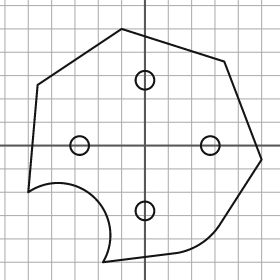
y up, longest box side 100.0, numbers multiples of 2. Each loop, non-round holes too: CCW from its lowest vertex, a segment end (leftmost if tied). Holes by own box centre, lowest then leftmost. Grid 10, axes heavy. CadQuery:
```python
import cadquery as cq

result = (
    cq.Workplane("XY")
    .moveTo(-18.0, -50.0)
    .lineTo(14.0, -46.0)
    .threePointArc((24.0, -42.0), (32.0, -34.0))
    .lineTo(50.0, -6.0)
    .lineTo(34.0, 36.0)
    .lineTo(-10.0, 50.0)
    .lineTo(-46.0, 26.0)
    .lineTo(-50.0, -20.0)
    .threePointArc((-22.0, -22.0), (-18.0, -50.0))
    .close()
    .moveTo(0.0, -28.0)
    .circle(4.0)
    .moveTo(-28.0, 0.0)
    .circle(4.0)
    .moveTo(28.0, 0.0)
    .circle(4.0)
    .moveTo(0.0, 28.0)
    .circle(4.0)
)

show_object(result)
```